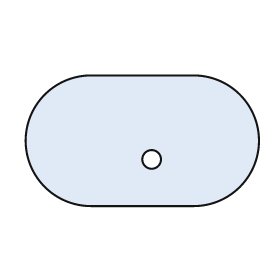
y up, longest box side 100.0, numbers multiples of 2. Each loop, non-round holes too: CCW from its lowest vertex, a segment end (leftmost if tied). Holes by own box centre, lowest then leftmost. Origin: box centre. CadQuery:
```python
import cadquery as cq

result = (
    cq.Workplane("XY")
    .moveTo(-22.0, -28.0)
    .lineTo(22.0, -28.0)
    .threePointArc((50.0, 0.0), (22.0, 28.0))
    .lineTo(-22.0, 28.0)
    .threePointArc((-50.0, 0.0), (-22.0, -28.0))
    .close()
    .moveTo(4.0, -8.0)
    .circle(4.0)
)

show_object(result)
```